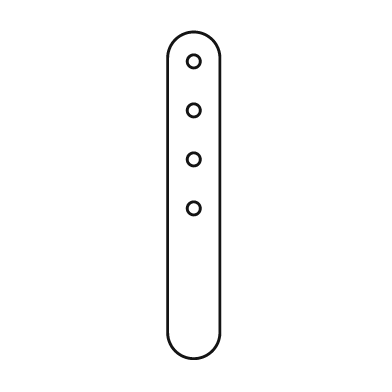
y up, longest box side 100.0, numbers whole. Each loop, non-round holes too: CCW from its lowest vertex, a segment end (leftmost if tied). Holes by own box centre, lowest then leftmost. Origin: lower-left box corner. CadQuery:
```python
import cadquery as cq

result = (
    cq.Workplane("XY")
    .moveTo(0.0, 8.0)
    .threePointArc((8.0, 0.0), (16.0, 8.0))
    .lineTo(16.0, 92.0)
    .threePointArc((8.0, 100.0), (0.0, 92.0))
    .close()
    .moveTo(8.0, 46.0)
    .circle(2.0)
    .moveTo(8.0, 61.0)
    .circle(2.0)
    .moveTo(8.0, 76.0)
    .circle(2.0)
    .moveTo(8.0, 91.0)
    .circle(2.0)
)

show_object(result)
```